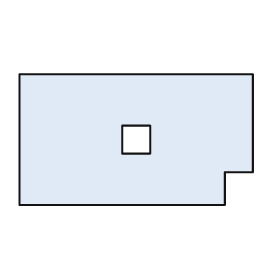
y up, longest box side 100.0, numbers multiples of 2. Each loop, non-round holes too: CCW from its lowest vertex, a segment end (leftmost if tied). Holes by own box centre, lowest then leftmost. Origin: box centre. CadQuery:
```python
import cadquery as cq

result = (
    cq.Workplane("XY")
    .moveTo(-50.0, -28.0)
    .lineTo(38.0, -28.0)
    .lineTo(38.0, -14.0)
    .lineTo(50.0, -14.0)
    .lineTo(50.0, 28.0)
    .lineTo(-50.0, 28.0)
    .close()
    .moveTo(-6.0, -6.0)
    .lineTo(6.0, -6.0)
    .lineTo(6.0, 6.0)
    .lineTo(-6.0, 6.0)
    .close()
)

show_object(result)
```